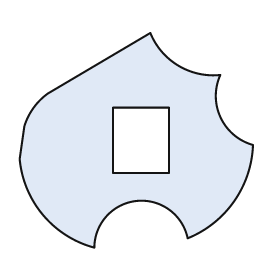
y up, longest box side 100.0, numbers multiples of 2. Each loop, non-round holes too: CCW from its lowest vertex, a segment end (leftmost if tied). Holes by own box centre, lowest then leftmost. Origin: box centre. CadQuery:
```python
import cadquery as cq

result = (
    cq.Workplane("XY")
    .moveTo(-18.0, -46.0)
    .threePointArc((0.0, -26.0), (22.0, -42.0))
    .threePointArc((42.0, -26.0), (50.0, -2.0))
    .threePointArc((36.0, 10.0), (36.0, 28.0))
    .threePointArc((18.0, 32.0), (6.0, 46.0))
    .lineTo(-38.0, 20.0)
    .threePointArc((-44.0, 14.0), (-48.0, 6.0))
    .lineTo(-50.0, -8.0)
    .threePointArc((-40.0, -32.0), (-18.0, -46.0))
    .close()
    .moveTo(-10.0, -14.0)
    .lineTo(14.0, -14.0)
    .lineTo(14.0, 14.0)
    .lineTo(-10.0, 14.0)
    .close()
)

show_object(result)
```